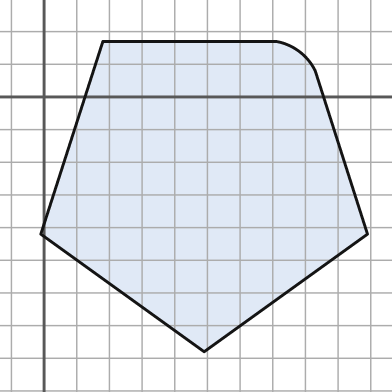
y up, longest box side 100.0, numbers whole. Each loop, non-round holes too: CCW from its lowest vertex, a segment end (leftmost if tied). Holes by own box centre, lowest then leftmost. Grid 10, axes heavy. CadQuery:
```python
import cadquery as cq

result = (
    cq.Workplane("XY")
    .moveTo(49.0, -78.0)
    .lineTo(99.0, -42.0)
    .lineTo(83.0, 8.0)
    .threePointArc((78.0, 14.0), (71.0, 17.0))
    .lineTo(18.0, 17.0)
    .lineTo(-1.0, -42.0)
    .close()
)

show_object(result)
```